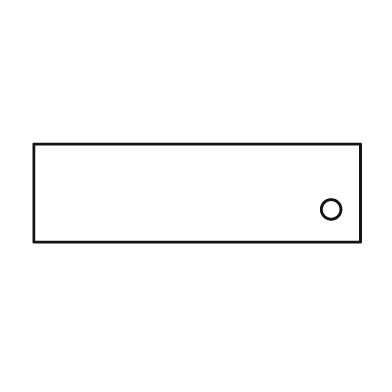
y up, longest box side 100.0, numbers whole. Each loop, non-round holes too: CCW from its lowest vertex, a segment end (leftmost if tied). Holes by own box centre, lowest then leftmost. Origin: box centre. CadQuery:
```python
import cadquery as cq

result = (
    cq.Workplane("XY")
    .moveTo(-50.0, -15.0)
    .lineTo(50.0, -15.0)
    .lineTo(50.0, 15.0)
    .lineTo(-50.0, 15.0)
    .close()
    .moveTo(41.0, -5.0)
    .circle(3.0)
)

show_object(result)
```